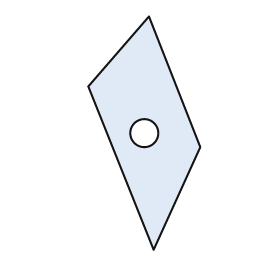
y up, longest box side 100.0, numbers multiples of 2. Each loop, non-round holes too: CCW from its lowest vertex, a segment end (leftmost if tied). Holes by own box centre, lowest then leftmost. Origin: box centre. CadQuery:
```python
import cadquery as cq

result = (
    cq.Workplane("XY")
    .moveTo(4.0, -50.0)
    .lineTo(24.0, -6.0)
    .lineTo(2.0, 50.0)
    .lineTo(-24.0, 20.0)
    .close()
    .moveTo(0.0, 0.0)
    .circle(6.0)
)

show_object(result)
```